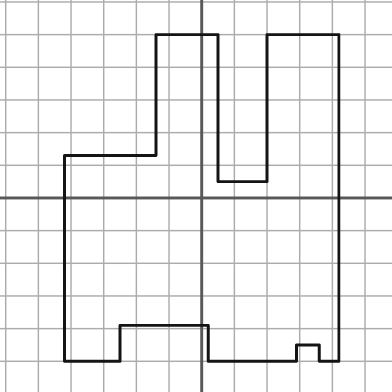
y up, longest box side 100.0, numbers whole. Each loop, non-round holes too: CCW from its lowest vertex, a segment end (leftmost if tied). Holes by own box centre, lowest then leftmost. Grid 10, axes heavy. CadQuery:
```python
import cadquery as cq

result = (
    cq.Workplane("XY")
    .moveTo(-42.0, -50.0)
    .lineTo(-25.0, -50.0)
    .lineTo(-25.0, -39.0)
    .lineTo(2.0, -39.0)
    .lineTo(2.0, -50.0)
    .lineTo(29.0, -50.0)
    .lineTo(29.0, -45.0)
    .lineTo(36.0, -45.0)
    .lineTo(36.0, -50.0)
    .lineTo(42.0, -50.0)
    .lineTo(42.0, 50.0)
    .lineTo(20.0, 50.0)
    .lineTo(20.0, 5.0)
    .lineTo(5.0, 5.0)
    .lineTo(5.0, 50.0)
    .lineTo(-14.0, 50.0)
    .lineTo(-14.0, 13.0)
    .lineTo(-42.0, 13.0)
    .close()
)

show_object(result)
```